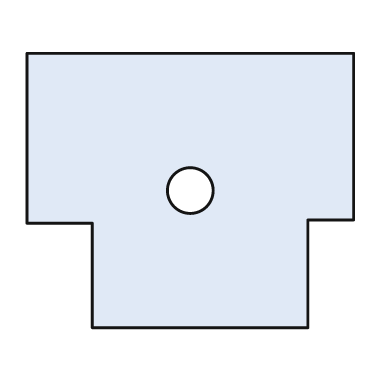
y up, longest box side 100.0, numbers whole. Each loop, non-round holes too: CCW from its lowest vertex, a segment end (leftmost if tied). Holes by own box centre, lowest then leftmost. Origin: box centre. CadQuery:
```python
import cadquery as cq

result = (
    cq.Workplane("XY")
    .moveTo(-30.0, -42.0)
    .lineTo(36.0, -42.0)
    .lineTo(36.0, -9.0)
    .lineTo(50.0, -9.0)
    .lineTo(50.0, 42.0)
    .lineTo(-50.0, 42.0)
    .lineTo(-50.0, -10.0)
    .lineTo(-30.0, -10.0)
    .close()
    .moveTo(0.0, 0.0)
    .circle(7.0)
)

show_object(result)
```